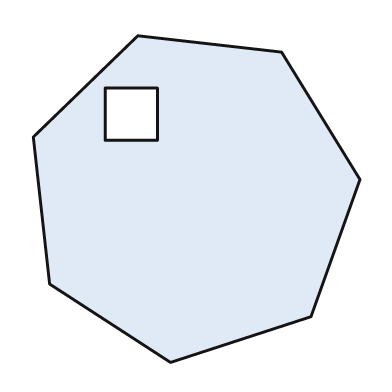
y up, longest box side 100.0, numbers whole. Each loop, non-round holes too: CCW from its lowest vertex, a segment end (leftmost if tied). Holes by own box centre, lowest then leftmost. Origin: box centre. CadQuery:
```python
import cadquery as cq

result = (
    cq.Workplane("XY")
    .moveTo(-8.0, -50.0)
    .lineTo(35.0, -36.0)
    .lineTo(50.0, 6.0)
    .lineTo(26.0, 45.0)
    .lineTo(-18.0, 50.0)
    .lineTo(-50.0, 19.0)
    .lineTo(-45.0, -26.0)
    .close()
    .moveTo(-28.0, 18.0)
    .lineTo(-12.0, 18.0)
    .lineTo(-12.0, 34.0)
    .lineTo(-28.0, 34.0)
    .close()
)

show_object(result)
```